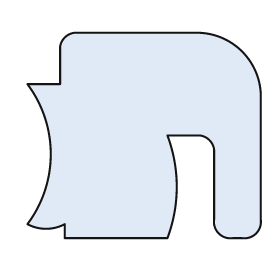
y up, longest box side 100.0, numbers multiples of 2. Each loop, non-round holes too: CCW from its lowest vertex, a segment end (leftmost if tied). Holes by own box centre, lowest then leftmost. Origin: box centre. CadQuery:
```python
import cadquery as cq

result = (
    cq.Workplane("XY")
    .moveTo(-34.0, -44.0)
    .lineTo(10.0, -44.0)
    .threePointArc((14.0, -22.0), (10.0, 0.0))
    .lineTo(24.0, 0.0)
    .threePointArc((28.0, -2.0), (30.0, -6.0))
    .lineTo(30.0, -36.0)
    .threePointArc((32.0, -42.0), (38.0, -44.0))
    .lineTo(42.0, -44.0)
    .threePointArc((48.0, -42.0), (50.0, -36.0))
    .lineTo(50.0, 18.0)
    .threePointArc((42.0, 36.0), (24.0, 44.0))
    .lineTo(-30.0, 44.0)
    .threePointArc((-34.0, 42.0), (-36.0, 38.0))
    .lineTo(-36.0, 22.0)
    .lineTo(-50.0, 22.0)
    .threePointArc((-40.0, -8.0), (-50.0, -38.0))
    .threePointArc((-42.0, -40.0), (-34.0, -38.0))
    .close()
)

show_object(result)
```